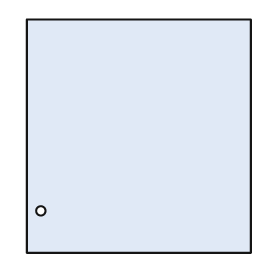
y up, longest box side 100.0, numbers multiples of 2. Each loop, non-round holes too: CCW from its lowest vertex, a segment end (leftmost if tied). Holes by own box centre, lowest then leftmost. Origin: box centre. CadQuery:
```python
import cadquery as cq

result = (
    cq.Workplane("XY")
    .moveTo(-48.0, -50.0)
    .lineTo(48.0, -50.0)
    .lineTo(48.0, 50.0)
    .lineTo(-48.0, 50.0)
    .close()
    .moveTo(-42.0, -32.0)
    .circle(2.0)
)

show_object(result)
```